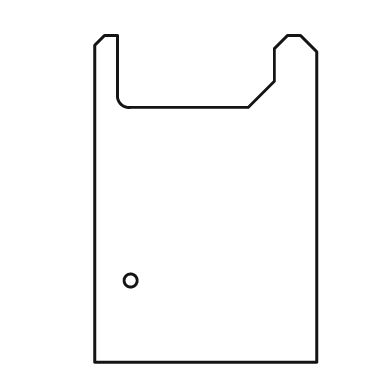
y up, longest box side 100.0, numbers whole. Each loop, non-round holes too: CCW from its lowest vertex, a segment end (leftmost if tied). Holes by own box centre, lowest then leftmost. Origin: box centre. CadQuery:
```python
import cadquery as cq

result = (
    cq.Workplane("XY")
    .moveTo(-34.0, -50.0)
    .lineTo(34.0, -50.0)
    .lineTo(34.0, 45.0)
    .lineTo(29.0, 50.0)
    .lineTo(25.0, 50.0)
    .lineTo(21.0, 46.0)
    .lineTo(21.0, 36.0)
    .lineTo(13.0, 28.0)
    .lineTo(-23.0, 28.0)
    .threePointArc((-26.0, 29.0), (-27.0, 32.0))
    .lineTo(-27.0, 50.0)
    .lineTo(-31.0, 50.0)
    .lineTo(-34.0, 47.0)
    .close()
    .moveTo(-23.0, -25.0)
    .circle(2.0)
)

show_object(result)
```